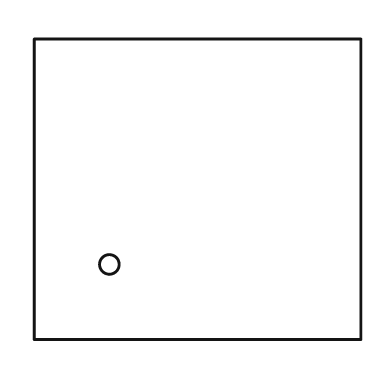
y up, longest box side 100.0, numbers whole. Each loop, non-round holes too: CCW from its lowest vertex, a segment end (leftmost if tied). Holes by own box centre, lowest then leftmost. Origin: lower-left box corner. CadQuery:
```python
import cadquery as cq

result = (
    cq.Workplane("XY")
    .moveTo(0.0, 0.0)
    .lineTo(100.0, 0.0)
    .lineTo(100.0, 92.0)
    .lineTo(0.0, 92.0)
    .close()
    .moveTo(23.0, 23.0)
    .circle(3.0)
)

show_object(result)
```